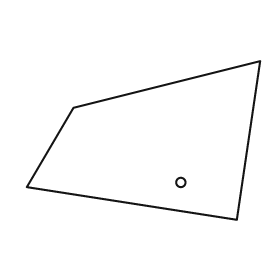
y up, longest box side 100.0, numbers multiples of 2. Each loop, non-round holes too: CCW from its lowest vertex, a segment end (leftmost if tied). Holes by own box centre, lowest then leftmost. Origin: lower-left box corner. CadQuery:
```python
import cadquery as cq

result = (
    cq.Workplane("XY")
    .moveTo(90.0, 0.0)
    .lineTo(100.0, 68.0)
    .lineTo(20.0, 48.0)
    .lineTo(0.0, 14.0)
    .close()
    .moveTo(66.0, 16.0)
    .circle(2.0)
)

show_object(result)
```